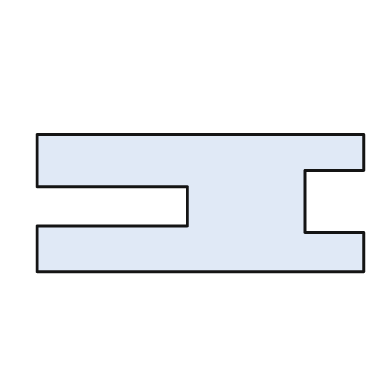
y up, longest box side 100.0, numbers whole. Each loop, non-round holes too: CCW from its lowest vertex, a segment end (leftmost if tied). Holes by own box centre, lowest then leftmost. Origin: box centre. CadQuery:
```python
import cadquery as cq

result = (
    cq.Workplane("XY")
    .moveTo(-50.0, -21.0)
    .lineTo(50.0, -21.0)
    .lineTo(50.0, -9.0)
    .lineTo(32.0, -9.0)
    .lineTo(32.0, 10.0)
    .lineTo(50.0, 10.0)
    .lineTo(50.0, 21.0)
    .lineTo(-50.0, 21.0)
    .lineTo(-50.0, 5.0)
    .lineTo(-4.0, 5.0)
    .lineTo(-4.0, -7.0)
    .lineTo(-50.0, -7.0)
    .close()
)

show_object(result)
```